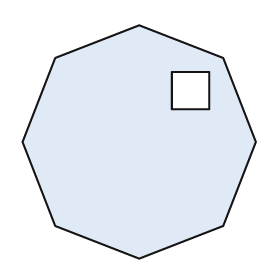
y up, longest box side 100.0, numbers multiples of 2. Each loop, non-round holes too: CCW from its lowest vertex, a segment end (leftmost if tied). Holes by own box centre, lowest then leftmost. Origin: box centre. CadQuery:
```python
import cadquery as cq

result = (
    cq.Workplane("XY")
    .moveTo(0.0, -50.0)
    .lineTo(36.0, -36.0)
    .lineTo(50.0, 0.0)
    .lineTo(36.0, 36.0)
    .lineTo(0.0, 50.0)
    .lineTo(-36.0, 36.0)
    .lineTo(-50.0, 0.0)
    .lineTo(-36.0, -36.0)
    .close()
    .moveTo(14.0, 14.0)
    .lineTo(30.0, 14.0)
    .lineTo(30.0, 30.0)
    .lineTo(14.0, 30.0)
    .close()
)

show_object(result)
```